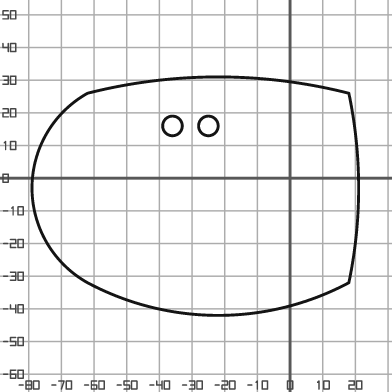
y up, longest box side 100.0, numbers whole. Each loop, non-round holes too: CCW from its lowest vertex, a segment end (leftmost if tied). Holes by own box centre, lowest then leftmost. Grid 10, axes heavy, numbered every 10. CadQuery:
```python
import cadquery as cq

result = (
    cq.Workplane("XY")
    .moveTo(-62.0, -32.0)
    .threePointArc((-22.0, -42.0), (18.0, -32.0))
    .threePointArc((21.0, -3.0), (18.0, 26.0))
    .threePointArc((-22.0, 31.0), (-62.0, 26.0))
    .threePointArc((-79.0, -3.0), (-62.0, -32.0))
    .close()
    .moveTo(-36.0, 16.0)
    .circle(3.0)
    .moveTo(-25.0, 16.0)
    .circle(3.0)
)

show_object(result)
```